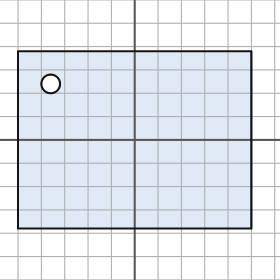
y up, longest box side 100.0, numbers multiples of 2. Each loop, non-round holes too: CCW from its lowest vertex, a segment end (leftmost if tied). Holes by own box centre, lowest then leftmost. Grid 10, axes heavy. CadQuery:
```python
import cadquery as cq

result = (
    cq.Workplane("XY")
    .moveTo(-50.0, -38.0)
    .lineTo(50.0, -38.0)
    .lineTo(50.0, 38.0)
    .lineTo(-50.0, 38.0)
    .close()
    .moveTo(-36.0, 24.0)
    .circle(4.0)
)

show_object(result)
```